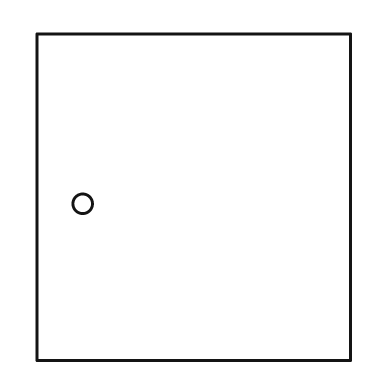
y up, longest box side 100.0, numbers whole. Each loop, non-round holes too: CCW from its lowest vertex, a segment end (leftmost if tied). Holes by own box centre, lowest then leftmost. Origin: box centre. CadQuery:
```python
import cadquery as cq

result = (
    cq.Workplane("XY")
    .moveTo(-48.0, -50.0)
    .lineTo(48.0, -50.0)
    .lineTo(48.0, 50.0)
    .lineTo(-48.0, 50.0)
    .close()
    .moveTo(-34.0, -2.0)
    .circle(3.0)
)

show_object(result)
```